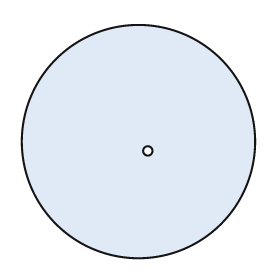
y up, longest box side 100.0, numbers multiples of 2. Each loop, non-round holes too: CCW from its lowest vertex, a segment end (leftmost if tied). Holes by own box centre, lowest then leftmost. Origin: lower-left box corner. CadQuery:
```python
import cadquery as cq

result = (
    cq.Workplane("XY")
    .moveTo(50.0, 50.0)
    .circle(50.0)
    .moveTo(54.0, 46.0)
    .circle(2.0)
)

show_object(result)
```